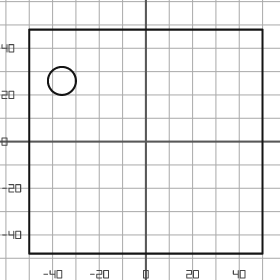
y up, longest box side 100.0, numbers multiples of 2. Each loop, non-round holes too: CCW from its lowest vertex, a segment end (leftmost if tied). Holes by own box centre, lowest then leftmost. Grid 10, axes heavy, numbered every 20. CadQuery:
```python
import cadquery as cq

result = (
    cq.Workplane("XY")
    .moveTo(-50.0, -48.0)
    .lineTo(50.0, -48.0)
    .lineTo(50.0, 48.0)
    .lineTo(-50.0, 48.0)
    .close()
    .moveTo(-36.0, 26.0)
    .circle(6.0)
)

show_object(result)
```